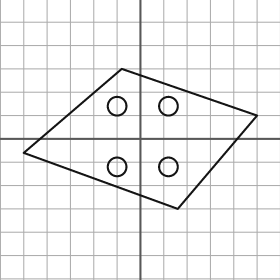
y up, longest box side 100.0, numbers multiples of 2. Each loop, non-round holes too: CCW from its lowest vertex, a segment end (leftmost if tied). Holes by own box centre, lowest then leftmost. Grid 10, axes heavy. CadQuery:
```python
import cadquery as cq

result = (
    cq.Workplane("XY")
    .moveTo(16.0, -30.0)
    .lineTo(50.0, 10.0)
    .lineTo(-8.0, 30.0)
    .lineTo(-50.0, -6.0)
    .close()
    .moveTo(-10.0, -12.0)
    .circle(4.0)
    .moveTo(12.0, -12.0)
    .circle(4.0)
    .moveTo(-10.0, 14.0)
    .circle(4.0)
    .moveTo(12.0, 14.0)
    .circle(4.0)
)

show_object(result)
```